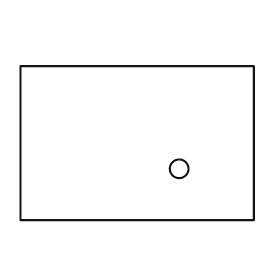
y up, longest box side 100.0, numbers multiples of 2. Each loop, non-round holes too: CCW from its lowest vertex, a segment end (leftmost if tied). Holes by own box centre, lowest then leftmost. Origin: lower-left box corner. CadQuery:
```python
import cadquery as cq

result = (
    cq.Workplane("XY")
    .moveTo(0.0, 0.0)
    .lineTo(100.0, 0.0)
    .lineTo(100.0, 66.0)
    .lineTo(0.0, 66.0)
    .close()
    .moveTo(68.0, 22.0)
    .circle(4.0)
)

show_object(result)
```